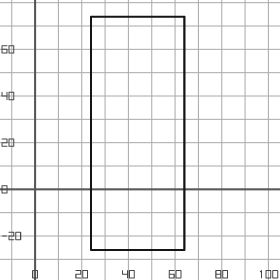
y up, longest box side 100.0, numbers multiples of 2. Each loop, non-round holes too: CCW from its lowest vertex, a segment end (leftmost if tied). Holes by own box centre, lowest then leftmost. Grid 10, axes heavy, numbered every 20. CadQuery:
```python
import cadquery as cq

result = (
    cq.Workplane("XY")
    .moveTo(24.0, -26.0)
    .lineTo(64.0, -26.0)
    .lineTo(64.0, 74.0)
    .lineTo(24.0, 74.0)
    .close()
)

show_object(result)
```